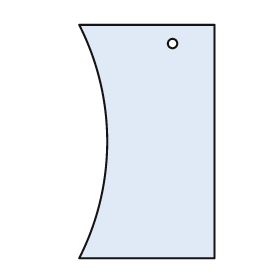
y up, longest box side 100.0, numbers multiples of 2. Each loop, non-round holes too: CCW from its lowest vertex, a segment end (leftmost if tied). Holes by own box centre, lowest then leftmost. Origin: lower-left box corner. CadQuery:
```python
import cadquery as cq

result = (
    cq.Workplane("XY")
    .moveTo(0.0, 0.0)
    .lineTo(58.0, 0.0)
    .lineTo(58.0, 100.0)
    .lineTo(0.0, 100.0)
    .threePointArc((12.0, 50.0), (0.0, 0.0))
    .close()
    .moveTo(40.0, 92.0)
    .circle(2.0)
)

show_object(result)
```